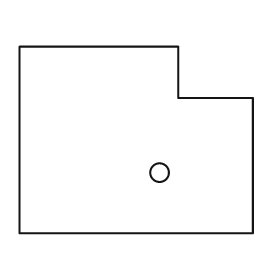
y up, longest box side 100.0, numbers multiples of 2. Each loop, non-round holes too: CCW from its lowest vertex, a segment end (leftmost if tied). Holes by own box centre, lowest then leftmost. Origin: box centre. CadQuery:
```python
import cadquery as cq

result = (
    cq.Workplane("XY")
    .moveTo(-50.0, -40.0)
    .lineTo(50.0, -40.0)
    .lineTo(50.0, 18.0)
    .lineTo(18.0, 18.0)
    .lineTo(18.0, 40.0)
    .lineTo(-50.0, 40.0)
    .close()
    .moveTo(10.0, -14.0)
    .circle(4.0)
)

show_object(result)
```